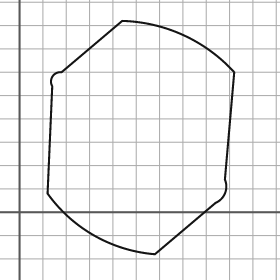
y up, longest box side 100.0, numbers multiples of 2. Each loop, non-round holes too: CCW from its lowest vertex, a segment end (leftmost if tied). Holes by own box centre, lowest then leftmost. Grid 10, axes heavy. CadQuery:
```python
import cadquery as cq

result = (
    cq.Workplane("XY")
    .moveTo(58.0, -18.0)
    .lineTo(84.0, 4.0)
    .threePointArc((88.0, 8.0), (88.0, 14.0))
    .lineTo(92.0, 60.0)
    .threePointArc((70.0, 76.0), (44.0, 82.0))
    .lineTo(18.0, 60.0)
    .threePointArc((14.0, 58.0), (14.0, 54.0))
    .lineTo(12.0, 8.0)
    .threePointArc((32.0, -10.0), (58.0, -18.0))
    .close()
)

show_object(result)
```